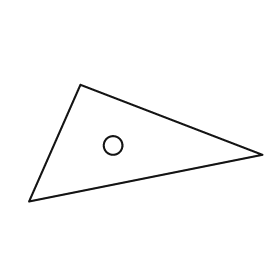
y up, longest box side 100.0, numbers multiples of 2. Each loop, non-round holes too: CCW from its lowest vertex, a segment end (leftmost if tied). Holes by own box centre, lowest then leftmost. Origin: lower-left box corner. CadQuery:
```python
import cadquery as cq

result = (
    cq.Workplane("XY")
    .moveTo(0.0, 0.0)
    .lineTo(100.0, 20.0)
    .lineTo(22.0, 50.0)
    .close()
    .moveTo(36.0, 24.0)
    .circle(4.0)
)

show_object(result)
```